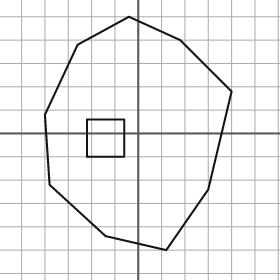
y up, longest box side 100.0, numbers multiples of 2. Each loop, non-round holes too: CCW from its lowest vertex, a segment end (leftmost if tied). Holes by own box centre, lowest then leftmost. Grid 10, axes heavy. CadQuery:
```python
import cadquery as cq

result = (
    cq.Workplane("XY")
    .moveTo(12.0, -50.0)
    .lineTo(30.0, -24.0)
    .lineTo(40.0, 18.0)
    .lineTo(18.0, 40.0)
    .lineTo(-4.0, 50.0)
    .lineTo(-26.0, 38.0)
    .lineTo(-40.0, 8.0)
    .lineTo(-38.0, -22.0)
    .lineTo(-14.0, -44.0)
    .close()
    .moveTo(-22.0, -10.0)
    .lineTo(-6.0, -10.0)
    .lineTo(-6.0, 6.0)
    .lineTo(-22.0, 6.0)
    .close()
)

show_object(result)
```